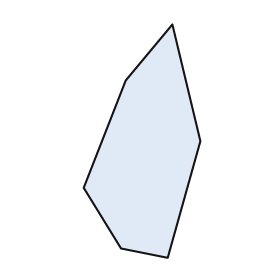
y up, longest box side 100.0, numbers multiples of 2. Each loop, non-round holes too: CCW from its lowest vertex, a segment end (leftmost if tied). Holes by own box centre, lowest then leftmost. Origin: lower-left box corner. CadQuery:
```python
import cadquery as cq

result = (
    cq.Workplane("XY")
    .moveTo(36.0, 0.0)
    .lineTo(50.0, 50.0)
    .lineTo(38.0, 100.0)
    .lineTo(18.0, 76.0)
    .lineTo(0.0, 30.0)
    .lineTo(16.0, 4.0)
    .close()
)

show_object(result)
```